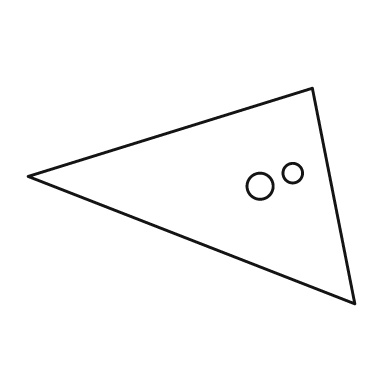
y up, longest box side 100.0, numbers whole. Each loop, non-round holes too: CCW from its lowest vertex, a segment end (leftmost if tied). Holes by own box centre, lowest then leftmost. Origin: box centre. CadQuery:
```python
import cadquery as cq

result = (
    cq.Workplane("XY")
    .moveTo(50.0, -33.0)
    .lineTo(37.0, 33.0)
    .lineTo(-50.0, 6.0)
    .close()
    .moveTo(21.0, 3.0)
    .circle(4.0)
    .moveTo(31.0, 7.0)
    .circle(3.0)
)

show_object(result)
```